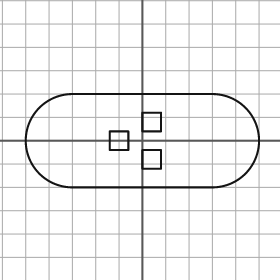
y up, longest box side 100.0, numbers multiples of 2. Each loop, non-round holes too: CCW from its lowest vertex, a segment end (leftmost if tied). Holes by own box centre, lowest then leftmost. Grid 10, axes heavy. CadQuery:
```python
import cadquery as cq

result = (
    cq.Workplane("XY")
    .moveTo(-30.0, -20.0)
    .lineTo(30.0, -20.0)
    .threePointArc((50.0, 0.0), (30.0, 20.0))
    .lineTo(-30.0, 20.0)
    .threePointArc((-50.0, 0.0), (-30.0, -20.0))
    .close()
    .moveTo(0.0, -12.0)
    .lineTo(8.0, -12.0)
    .lineTo(8.0, -4.0)
    .lineTo(0.0, -4.0)
    .close()
    .moveTo(-14.0, -4.0)
    .lineTo(-6.0, -4.0)
    .lineTo(-6.0, 4.0)
    .lineTo(-14.0, 4.0)
    .close()
    .moveTo(0.0, 4.0)
    .lineTo(8.0, 4.0)
    .lineTo(8.0, 12.0)
    .lineTo(0.0, 12.0)
    .close()
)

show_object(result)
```